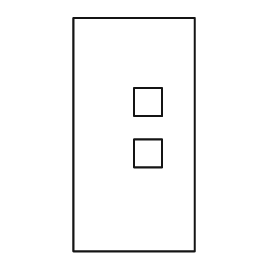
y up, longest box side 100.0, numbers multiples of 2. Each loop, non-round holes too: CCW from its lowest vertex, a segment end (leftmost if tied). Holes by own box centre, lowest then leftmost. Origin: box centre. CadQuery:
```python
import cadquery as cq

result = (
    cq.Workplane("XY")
    .moveTo(-26.0, -50.0)
    .lineTo(26.0, -50.0)
    .lineTo(26.0, 50.0)
    .lineTo(-26.0, 50.0)
    .close()
    .moveTo(0.0, -14.0)
    .lineTo(12.0, -14.0)
    .lineTo(12.0, -2.0)
    .lineTo(0.0, -2.0)
    .close()
    .moveTo(0.0, 8.0)
    .lineTo(12.0, 8.0)
    .lineTo(12.0, 20.0)
    .lineTo(0.0, 20.0)
    .close()
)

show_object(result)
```